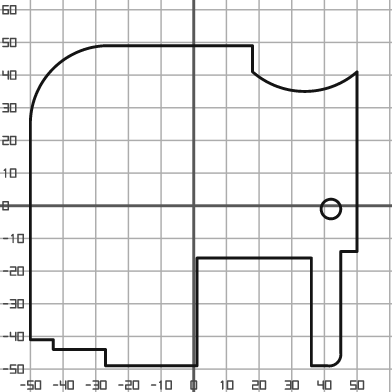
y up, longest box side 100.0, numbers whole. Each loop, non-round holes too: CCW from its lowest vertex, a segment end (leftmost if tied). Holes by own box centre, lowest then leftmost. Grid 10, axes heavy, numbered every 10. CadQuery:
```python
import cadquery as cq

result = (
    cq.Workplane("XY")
    .moveTo(-27.0, -49.0)
    .lineTo(1.0, -49.0)
    .lineTo(1.0, -16.0)
    .lineTo(36.0, -16.0)
    .lineTo(36.0, -49.0)
    .lineTo(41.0, -49.0)
    .threePointArc((44.0, -48.0), (45.0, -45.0))
    .lineTo(45.0, -14.0)
    .lineTo(50.0, -14.0)
    .lineTo(50.0, 41.0)
    .threePointArc((34.0, 35.0), (18.0, 41.0))
    .lineTo(18.0, 49.0)
    .lineTo(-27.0, 49.0)
    .threePointArc((-43.0, 42.0), (-50.0, 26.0))
    .lineTo(-50.0, -41.0)
    .lineTo(-43.0, -41.0)
    .lineTo(-43.0, -44.0)
    .lineTo(-27.0, -44.0)
    .close()
    .moveTo(42.0, -1.0)
    .circle(3.0)
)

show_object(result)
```